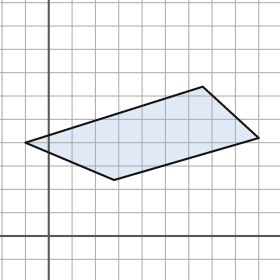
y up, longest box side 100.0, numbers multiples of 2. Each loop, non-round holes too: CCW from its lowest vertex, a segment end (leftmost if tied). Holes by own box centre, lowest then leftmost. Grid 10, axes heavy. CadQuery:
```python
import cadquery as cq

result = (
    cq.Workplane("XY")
    .moveTo(28.0, 24.0)
    .lineTo(90.0, 42.0)
    .lineTo(66.0, 64.0)
    .lineTo(-10.0, 40.0)
    .close()
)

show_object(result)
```